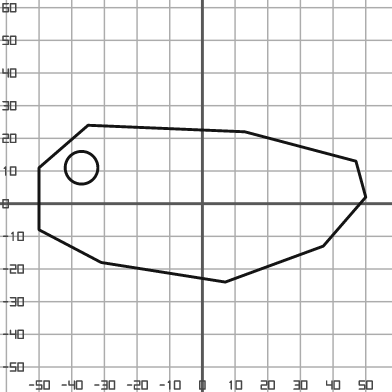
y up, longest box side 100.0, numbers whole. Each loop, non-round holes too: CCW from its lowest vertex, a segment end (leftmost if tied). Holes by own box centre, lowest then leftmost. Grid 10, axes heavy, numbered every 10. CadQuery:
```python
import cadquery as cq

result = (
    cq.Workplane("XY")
    .moveTo(7.0, -24.0)
    .lineTo(37.0, -13.0)
    .lineTo(50.0, 2.0)
    .lineTo(47.0, 13.0)
    .lineTo(13.0, 22.0)
    .lineTo(-35.0, 24.0)
    .lineTo(-50.0, 11.0)
    .lineTo(-50.0, -8.0)
    .lineTo(-31.0, -18.0)
    .close()
    .moveTo(-37.0, 11.0)
    .circle(5.0)
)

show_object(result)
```